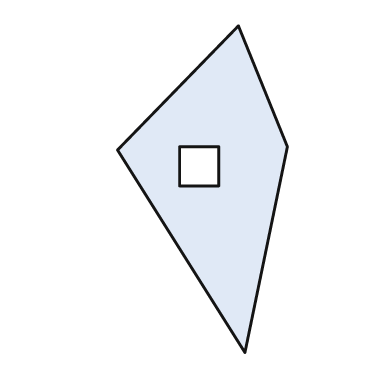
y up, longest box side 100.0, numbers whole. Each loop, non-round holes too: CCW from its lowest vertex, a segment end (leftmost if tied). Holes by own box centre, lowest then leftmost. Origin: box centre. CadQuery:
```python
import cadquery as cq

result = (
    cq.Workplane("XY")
    .moveTo(13.0, -50.0)
    .lineTo(26.0, 13.0)
    .lineTo(11.0, 50.0)
    .lineTo(-26.0, 12.0)
    .close()
    .moveTo(-7.0, 1.0)
    .lineTo(5.0, 1.0)
    .lineTo(5.0, 13.0)
    .lineTo(-7.0, 13.0)
    .close()
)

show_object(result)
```